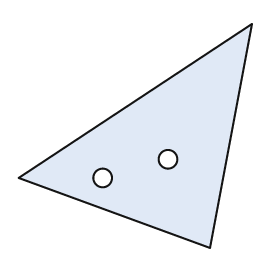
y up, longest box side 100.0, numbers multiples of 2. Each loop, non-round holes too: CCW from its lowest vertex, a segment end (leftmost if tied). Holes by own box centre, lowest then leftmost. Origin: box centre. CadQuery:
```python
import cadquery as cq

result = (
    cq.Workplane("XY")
    .moveTo(32.0, -48.0)
    .lineTo(50.0, 48.0)
    .lineTo(-50.0, -18.0)
    .close()
    .moveTo(-14.0, -18.0)
    .circle(4.0)
    .moveTo(14.0, -10.0)
    .circle(4.0)
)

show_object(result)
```